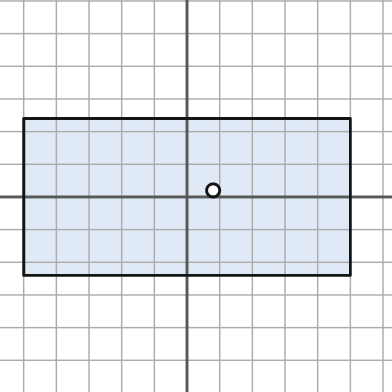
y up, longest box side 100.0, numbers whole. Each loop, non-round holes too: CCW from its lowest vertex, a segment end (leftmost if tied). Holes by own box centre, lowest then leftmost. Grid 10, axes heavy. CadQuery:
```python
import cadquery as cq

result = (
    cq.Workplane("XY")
    .moveTo(-50.0, -24.0)
    .lineTo(50.0, -24.0)
    .lineTo(50.0, 24.0)
    .lineTo(-50.0, 24.0)
    .close()
    .moveTo(8.0, 2.0)
    .circle(2.0)
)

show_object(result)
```